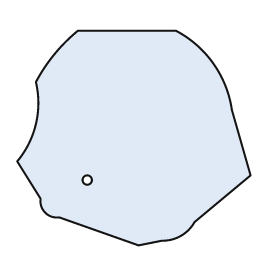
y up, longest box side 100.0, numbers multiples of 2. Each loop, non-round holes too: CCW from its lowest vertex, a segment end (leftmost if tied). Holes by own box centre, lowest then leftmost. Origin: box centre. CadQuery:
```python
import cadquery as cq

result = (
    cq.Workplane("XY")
    .moveTo(2.0, -46.0)
    .lineTo(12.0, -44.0)
    .threePointArc((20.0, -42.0), (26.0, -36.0))
    .lineTo(50.0, -16.0)
    .lineTo(42.0, 12.0)
    .threePointArc((34.0, 32.0), (18.0, 46.0))
    .lineTo(-24.0, 46.0)
    .threePointArc((-34.0, 36.0), (-42.0, 24.0))
    .threePointArc((-42.0, 6.0), (-50.0, -10.0))
    .lineTo(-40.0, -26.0)
    .threePointArc((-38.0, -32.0), (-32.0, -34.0))
    .close()
    .moveTo(-20.0, -18.0)
    .circle(2.0)
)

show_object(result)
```